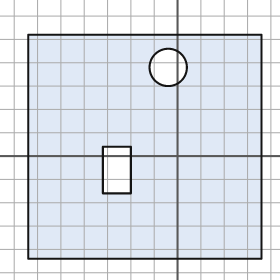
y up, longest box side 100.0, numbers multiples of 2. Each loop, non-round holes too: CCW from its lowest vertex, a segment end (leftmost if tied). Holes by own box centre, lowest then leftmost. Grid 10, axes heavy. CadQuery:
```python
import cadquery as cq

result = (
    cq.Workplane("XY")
    .moveTo(-64.0, -44.0)
    .lineTo(36.0, -44.0)
    .lineTo(36.0, 52.0)
    .lineTo(-64.0, 52.0)
    .close()
    .moveTo(-32.0, -16.0)
    .lineTo(-20.0, -16.0)
    .lineTo(-20.0, 4.0)
    .lineTo(-32.0, 4.0)
    .close()
    .moveTo(-4.0, 38.0)
    .circle(8.0)
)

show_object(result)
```